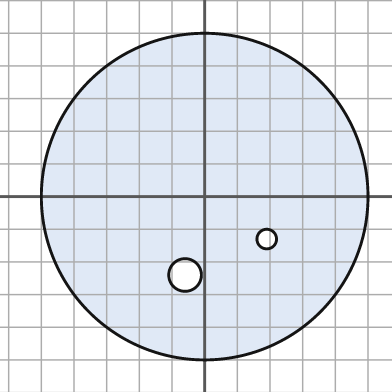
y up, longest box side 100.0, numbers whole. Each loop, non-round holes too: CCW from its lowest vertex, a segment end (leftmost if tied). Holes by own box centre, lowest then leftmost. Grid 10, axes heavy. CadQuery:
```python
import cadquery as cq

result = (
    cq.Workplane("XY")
    .moveTo(0.0, 0.0)
    .circle(50.0)
    .moveTo(-6.0, -24.0)
    .circle(5.0)
    .moveTo(19.0, -13.0)
    .circle(3.0)
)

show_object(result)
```